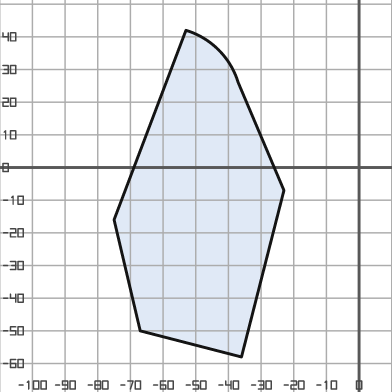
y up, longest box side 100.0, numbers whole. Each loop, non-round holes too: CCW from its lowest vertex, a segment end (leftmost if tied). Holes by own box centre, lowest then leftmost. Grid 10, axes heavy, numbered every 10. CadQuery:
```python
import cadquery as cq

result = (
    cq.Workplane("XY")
    .moveTo(-36.0, -58.0)
    .lineTo(-23.0, -7.0)
    .lineTo(-37.0, 26.0)
    .threePointArc((-43.0, 36.0), (-53.0, 42.0))
    .lineTo(-75.0, -16.0)
    .lineTo(-67.0, -50.0)
    .close()
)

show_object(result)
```